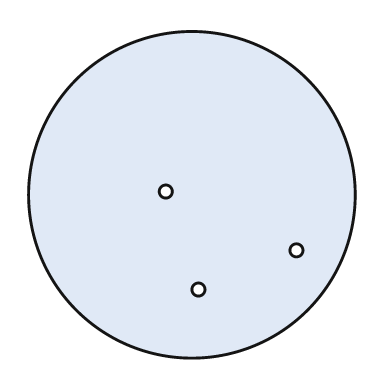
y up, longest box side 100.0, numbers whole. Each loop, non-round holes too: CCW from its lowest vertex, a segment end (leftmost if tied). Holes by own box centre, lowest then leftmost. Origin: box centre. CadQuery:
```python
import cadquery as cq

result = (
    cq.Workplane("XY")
    .moveTo(0.0, 0.0)
    .circle(50.0)
    .moveTo(2.0, -29.0)
    .circle(2.0)
    .moveTo(32.0, -17.0)
    .circle(2.0)
    .moveTo(-8.0, 1.0)
    .circle(2.0)
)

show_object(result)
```